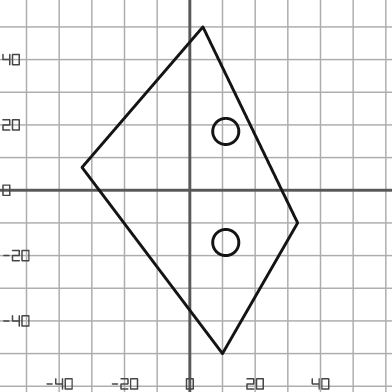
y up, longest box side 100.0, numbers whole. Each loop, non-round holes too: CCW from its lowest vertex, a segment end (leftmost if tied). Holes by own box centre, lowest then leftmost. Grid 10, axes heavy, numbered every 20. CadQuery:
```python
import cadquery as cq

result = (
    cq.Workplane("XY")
    .moveTo(10.0, -50.0)
    .lineTo(33.0, -10.0)
    .lineTo(4.0, 50.0)
    .lineTo(-33.0, 7.0)
    .close()
    .moveTo(11.0, -16.0)
    .circle(4.0)
    .moveTo(11.0, 18.0)
    .circle(4.0)
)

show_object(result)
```